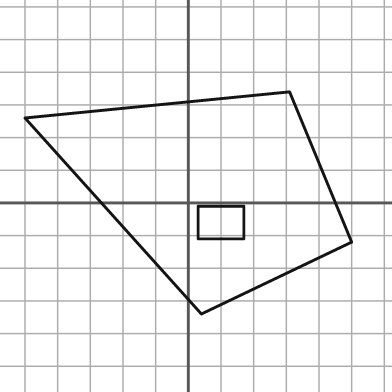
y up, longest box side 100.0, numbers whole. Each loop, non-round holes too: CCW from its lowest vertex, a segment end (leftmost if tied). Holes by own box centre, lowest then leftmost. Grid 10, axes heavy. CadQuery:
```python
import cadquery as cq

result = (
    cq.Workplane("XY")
    .moveTo(4.0, -34.0)
    .lineTo(50.0, -12.0)
    .lineTo(31.0, 34.0)
    .lineTo(-50.0, 26.0)
    .close()
    .moveTo(3.0, -11.0)
    .lineTo(17.0, -11.0)
    .lineTo(17.0, -1.0)
    .lineTo(3.0, -1.0)
    .close()
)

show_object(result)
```